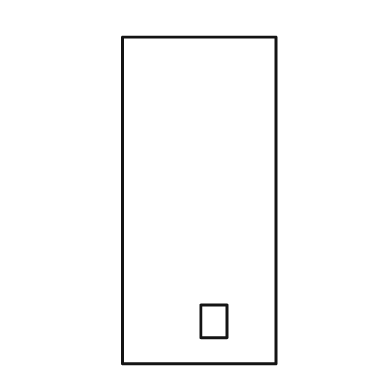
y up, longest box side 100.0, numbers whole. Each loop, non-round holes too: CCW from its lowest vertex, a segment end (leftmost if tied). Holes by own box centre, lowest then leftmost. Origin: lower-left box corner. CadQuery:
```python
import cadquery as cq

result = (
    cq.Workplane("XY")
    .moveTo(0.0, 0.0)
    .lineTo(47.0, 0.0)
    .lineTo(47.0, 100.0)
    .lineTo(0.0, 100.0)
    .close()
    .moveTo(24.0, 8.0)
    .lineTo(32.0, 8.0)
    .lineTo(32.0, 18.0)
    .lineTo(24.0, 18.0)
    .close()
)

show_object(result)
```